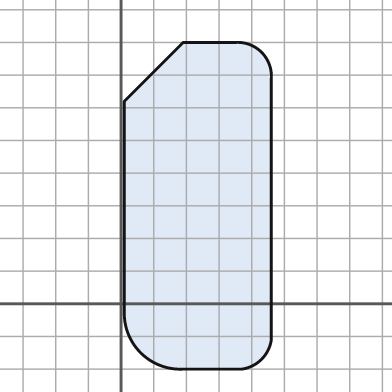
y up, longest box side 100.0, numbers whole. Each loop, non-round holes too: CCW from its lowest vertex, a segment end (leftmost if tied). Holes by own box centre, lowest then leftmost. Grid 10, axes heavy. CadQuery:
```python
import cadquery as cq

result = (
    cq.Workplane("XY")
    .moveTo(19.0, -20.0)
    .lineTo(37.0, -20.0)
    .threePointArc((43.0, -17.0), (46.0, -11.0))
    .lineTo(46.0, 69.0)
    .threePointArc((43.0, 77.0), (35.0, 80.0))
    .lineTo(19.0, 80.0)
    .lineTo(1.0, 62.0)
    .lineTo(1.0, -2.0)
    .threePointArc((6.0, -15.0), (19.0, -20.0))
    .close()
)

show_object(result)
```